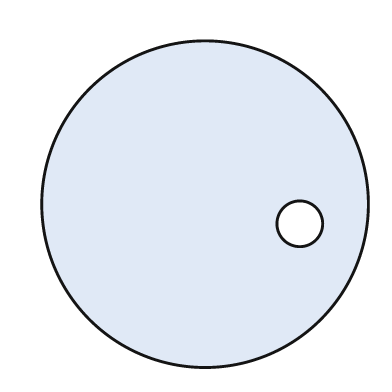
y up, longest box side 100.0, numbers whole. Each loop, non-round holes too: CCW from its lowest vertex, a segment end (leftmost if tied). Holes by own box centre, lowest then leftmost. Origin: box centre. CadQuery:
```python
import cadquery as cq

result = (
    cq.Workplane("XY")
    .moveTo(0.0, 0.0)
    .circle(50.0)
    .moveTo(29.0, -6.0)
    .circle(7.0)
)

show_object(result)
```